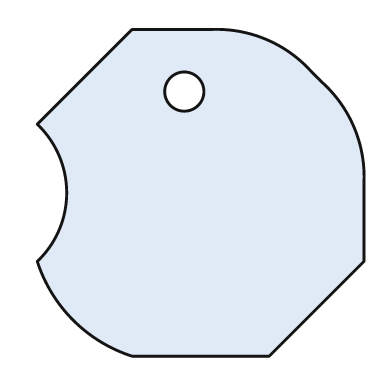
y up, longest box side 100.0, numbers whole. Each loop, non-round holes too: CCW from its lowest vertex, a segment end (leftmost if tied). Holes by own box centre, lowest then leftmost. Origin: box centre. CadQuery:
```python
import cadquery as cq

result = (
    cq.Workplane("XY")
    .moveTo(-21.0, -50.0)
    .lineTo(21.0, -50.0)
    .lineTo(50.0, -21.0)
    .lineTo(50.0, 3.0)
    .threePointArc((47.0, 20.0), (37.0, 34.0))
    .lineTo(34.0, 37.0)
    .threePointArc((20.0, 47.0), (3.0, 50.0))
    .lineTo(-21.0, 50.0)
    .lineTo(-50.0, 21.0)
    .threePointArc((-41.0, 0.0), (-50.0, -21.0))
    .threePointArc((-39.0, -39.0), (-21.0, -50.0))
    .close()
    .moveTo(-5.0, 31.0)
    .circle(6.0)
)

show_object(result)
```